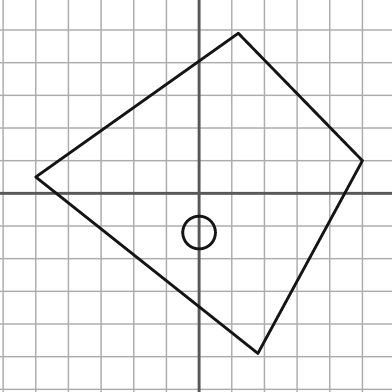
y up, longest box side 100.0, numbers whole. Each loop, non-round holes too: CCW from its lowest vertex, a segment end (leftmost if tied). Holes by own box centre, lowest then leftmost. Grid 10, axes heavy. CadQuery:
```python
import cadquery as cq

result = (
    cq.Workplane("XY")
    .moveTo(18.0, -49.0)
    .lineTo(50.0, 10.0)
    .lineTo(12.0, 49.0)
    .lineTo(-50.0, 5.0)
    .close()
    .moveTo(0.0, -12.0)
    .circle(5.0)
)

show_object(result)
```